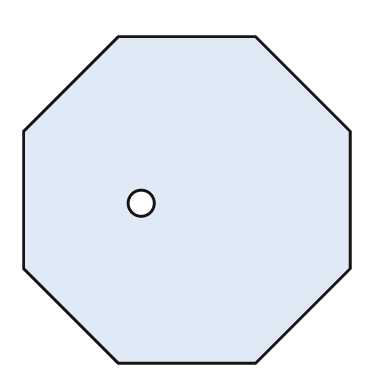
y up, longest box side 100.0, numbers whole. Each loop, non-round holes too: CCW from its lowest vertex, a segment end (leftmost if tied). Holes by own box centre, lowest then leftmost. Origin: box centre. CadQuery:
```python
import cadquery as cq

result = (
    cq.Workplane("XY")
    .moveTo(-21.0, -50.0)
    .lineTo(21.0, -50.0)
    .lineTo(50.0, -21.0)
    .lineTo(50.0, 21.0)
    .lineTo(21.0, 50.0)
    .lineTo(-21.0, 50.0)
    .lineTo(-50.0, 21.0)
    .lineTo(-50.0, -21.0)
    .close()
    .moveTo(-14.0, -1.0)
    .circle(4.0)
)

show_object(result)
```